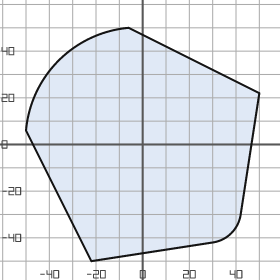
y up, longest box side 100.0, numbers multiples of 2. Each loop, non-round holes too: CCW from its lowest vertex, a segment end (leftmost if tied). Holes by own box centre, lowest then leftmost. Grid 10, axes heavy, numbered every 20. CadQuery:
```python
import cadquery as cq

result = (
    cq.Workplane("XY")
    .moveTo(-22.0, -50.0)
    .lineTo(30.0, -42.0)
    .threePointArc((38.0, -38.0), (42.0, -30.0))
    .lineTo(50.0, 22.0)
    .lineTo(-6.0, 50.0)
    .threePointArc((-36.0, 36.0), (-50.0, 6.0))
    .close()
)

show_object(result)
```